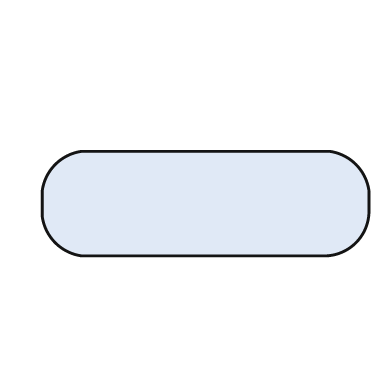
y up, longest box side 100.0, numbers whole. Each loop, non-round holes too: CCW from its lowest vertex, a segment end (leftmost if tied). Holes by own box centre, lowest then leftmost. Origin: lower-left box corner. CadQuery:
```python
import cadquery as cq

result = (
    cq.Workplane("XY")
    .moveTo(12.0, 0.0)
    .lineTo(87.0, 0.0)
    .threePointArc((96.0, 4.0), (100.0, 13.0))
    .lineTo(100.0, 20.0)
    .threePointArc((96.0, 28.0), (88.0, 32.0))
    .lineTo(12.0, 32.0)
    .threePointArc((4.0, 28.0), (0.0, 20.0))
    .lineTo(0.0, 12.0)
    .threePointArc((4.0, 4.0), (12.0, 0.0))
    .close()
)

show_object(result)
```